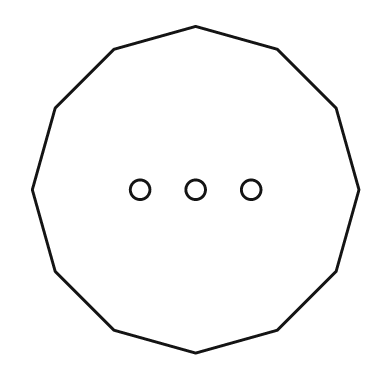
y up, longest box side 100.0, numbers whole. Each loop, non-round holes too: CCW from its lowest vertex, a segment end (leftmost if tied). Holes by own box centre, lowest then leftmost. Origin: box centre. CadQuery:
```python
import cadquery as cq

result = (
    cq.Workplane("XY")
    .moveTo(0.0, -50.0)
    .lineTo(25.0, -43.0)
    .lineTo(43.0, -25.0)
    .lineTo(50.0, 0.0)
    .lineTo(43.0, 25.0)
    .lineTo(25.0, 43.0)
    .lineTo(0.0, 50.0)
    .lineTo(-25.0, 43.0)
    .lineTo(-43.0, 25.0)
    .lineTo(-50.0, 0.0)
    .lineTo(-43.0, -25.0)
    .lineTo(-25.0, -43.0)
    .close()
    .moveTo(-17.0, 0.0)
    .circle(3.0)
    .moveTo(0.0, 0.0)
    .circle(3.0)
    .moveTo(17.0, 0.0)
    .circle(3.0)
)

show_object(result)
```